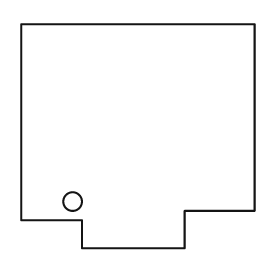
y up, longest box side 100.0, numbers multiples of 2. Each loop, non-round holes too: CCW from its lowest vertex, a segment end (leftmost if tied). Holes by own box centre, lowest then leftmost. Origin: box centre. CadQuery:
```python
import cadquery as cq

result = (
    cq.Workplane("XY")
    .moveTo(-24.0, -48.0)
    .lineTo(20.0, -48.0)
    .lineTo(20.0, -32.0)
    .lineTo(50.0, -32.0)
    .lineTo(50.0, 48.0)
    .lineTo(-50.0, 48.0)
    .lineTo(-50.0, -36.0)
    .lineTo(-24.0, -36.0)
    .close()
    .moveTo(-28.0, -28.0)
    .circle(4.0)
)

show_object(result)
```